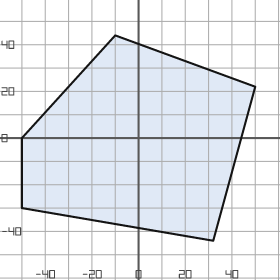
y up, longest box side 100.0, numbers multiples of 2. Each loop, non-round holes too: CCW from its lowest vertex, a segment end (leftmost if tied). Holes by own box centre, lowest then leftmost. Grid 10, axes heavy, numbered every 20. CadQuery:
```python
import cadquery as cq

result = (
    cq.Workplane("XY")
    .moveTo(32.0, -44.0)
    .lineTo(50.0, 22.0)
    .lineTo(-10.0, 44.0)
    .lineTo(-50.0, 0.0)
    .lineTo(-50.0, -30.0)
    .close()
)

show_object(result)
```